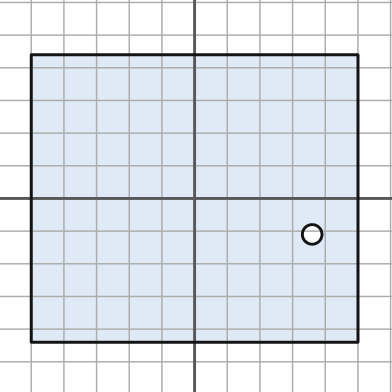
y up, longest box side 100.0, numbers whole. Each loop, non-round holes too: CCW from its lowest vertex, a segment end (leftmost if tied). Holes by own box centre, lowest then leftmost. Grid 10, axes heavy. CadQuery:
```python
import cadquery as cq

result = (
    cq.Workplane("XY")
    .moveTo(-50.0, -44.0)
    .lineTo(50.0, -44.0)
    .lineTo(50.0, 44.0)
    .lineTo(-50.0, 44.0)
    .close()
    .moveTo(36.0, -11.0)
    .circle(3.0)
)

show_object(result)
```